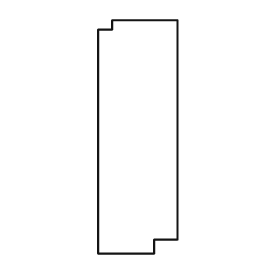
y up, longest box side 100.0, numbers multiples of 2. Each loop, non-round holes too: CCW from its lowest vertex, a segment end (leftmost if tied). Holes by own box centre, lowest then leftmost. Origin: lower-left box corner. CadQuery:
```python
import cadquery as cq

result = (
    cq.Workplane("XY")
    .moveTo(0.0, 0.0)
    .lineTo(24.0, 0.0)
    .lineTo(24.0, 6.0)
    .lineTo(34.0, 6.0)
    .lineTo(34.0, 100.0)
    .lineTo(6.0, 100.0)
    .lineTo(6.0, 96.0)
    .lineTo(0.0, 96.0)
    .close()
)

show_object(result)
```